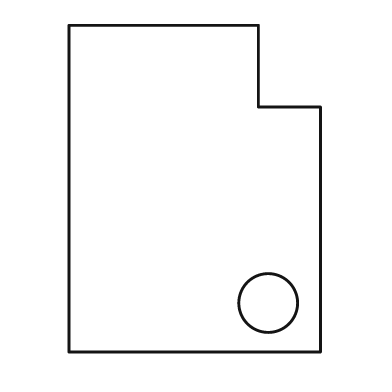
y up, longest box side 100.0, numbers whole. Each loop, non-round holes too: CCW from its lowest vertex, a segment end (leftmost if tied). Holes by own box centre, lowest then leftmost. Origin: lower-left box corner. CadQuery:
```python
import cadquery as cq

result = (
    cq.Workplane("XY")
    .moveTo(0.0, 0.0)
    .lineTo(77.0, 0.0)
    .lineTo(77.0, 75.0)
    .lineTo(58.0, 75.0)
    .lineTo(58.0, 100.0)
    .lineTo(0.0, 100.0)
    .close()
    .moveTo(61.0, 15.0)
    .circle(9.0)
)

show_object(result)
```